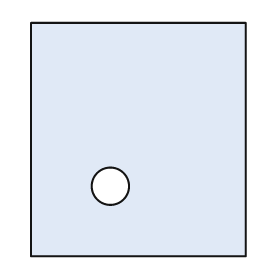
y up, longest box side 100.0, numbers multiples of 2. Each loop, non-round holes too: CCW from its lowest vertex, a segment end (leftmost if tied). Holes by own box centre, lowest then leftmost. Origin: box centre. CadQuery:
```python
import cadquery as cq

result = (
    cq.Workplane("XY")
    .moveTo(-46.0, -50.0)
    .lineTo(46.0, -50.0)
    .lineTo(46.0, 50.0)
    .lineTo(-46.0, 50.0)
    .close()
    .moveTo(-12.0, -20.0)
    .circle(8.0)
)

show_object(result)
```